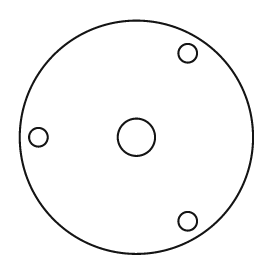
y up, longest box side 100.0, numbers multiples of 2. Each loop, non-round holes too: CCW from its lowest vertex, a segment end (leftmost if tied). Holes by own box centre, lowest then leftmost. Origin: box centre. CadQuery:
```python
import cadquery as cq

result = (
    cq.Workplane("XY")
    .moveTo(0.0, 0.0)
    .circle(50.0)
    .moveTo(22.0, -36.0)
    .circle(4.0)
    .moveTo(-42.0, 0.0)
    .circle(4.0)
    .moveTo(0.0, 0.0)
    .circle(8.0)
    .moveTo(22.0, 36.0)
    .circle(4.0)
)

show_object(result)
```